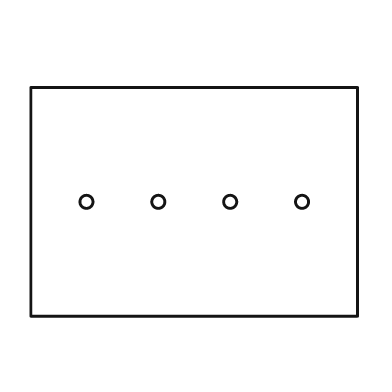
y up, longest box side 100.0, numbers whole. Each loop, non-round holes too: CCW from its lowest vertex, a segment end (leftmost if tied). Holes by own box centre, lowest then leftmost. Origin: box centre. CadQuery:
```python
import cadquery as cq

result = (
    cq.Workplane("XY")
    .moveTo(-50.0, -35.0)
    .lineTo(50.0, -35.0)
    .lineTo(50.0, 35.0)
    .lineTo(-50.0, 35.0)
    .close()
    .moveTo(-33.0, 0.0)
    .circle(2.0)
    .moveTo(-11.0, 0.0)
    .circle(2.0)
    .moveTo(11.0, 0.0)
    .circle(2.0)
    .moveTo(33.0, 0.0)
    .circle(2.0)
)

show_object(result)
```